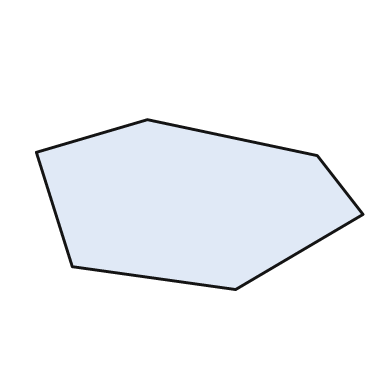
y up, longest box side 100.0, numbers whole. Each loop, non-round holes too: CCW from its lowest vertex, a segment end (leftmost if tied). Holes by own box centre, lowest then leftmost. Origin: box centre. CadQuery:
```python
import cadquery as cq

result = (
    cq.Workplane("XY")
    .moveTo(11.0, -26.0)
    .lineTo(50.0, -3.0)
    .lineTo(36.0, 15.0)
    .lineTo(-16.0, 26.0)
    .lineTo(-50.0, 16.0)
    .lineTo(-39.0, -19.0)
    .close()
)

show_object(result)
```